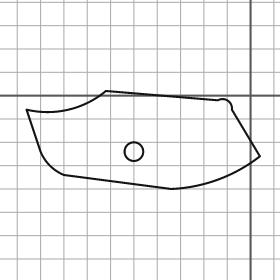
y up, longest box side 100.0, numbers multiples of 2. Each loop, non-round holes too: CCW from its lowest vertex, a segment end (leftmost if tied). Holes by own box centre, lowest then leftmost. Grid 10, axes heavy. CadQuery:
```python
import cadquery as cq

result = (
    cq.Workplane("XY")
    .moveTo(-34.0, -40.0)
    .threePointArc((-14.0, -36.0), (4.0, -26.0))
    .lineTo(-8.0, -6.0)
    .threePointArc((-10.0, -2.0), (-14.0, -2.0))
    .lineTo(-62.0, 2.0)
    .threePointArc((-78.0, -6.0), (-96.0, -6.0))
    .lineTo(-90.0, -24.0)
    .threePointArc((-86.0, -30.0), (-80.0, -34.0))
    .close()
    .moveTo(-50.0, -24.0)
    .circle(4.0)
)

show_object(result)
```